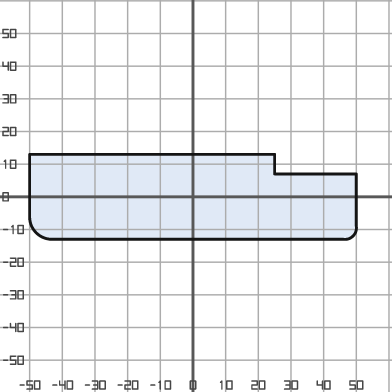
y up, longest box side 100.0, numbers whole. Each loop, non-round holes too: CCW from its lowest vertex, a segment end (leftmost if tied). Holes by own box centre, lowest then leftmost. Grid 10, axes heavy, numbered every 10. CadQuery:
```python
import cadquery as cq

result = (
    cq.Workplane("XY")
    .moveTo(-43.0, -13.0)
    .lineTo(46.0, -13.0)
    .threePointArc((49.0, -12.0), (50.0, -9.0))
    .lineTo(50.0, 7.0)
    .lineTo(25.0, 7.0)
    .lineTo(25.0, 13.0)
    .lineTo(-50.0, 13.0)
    .lineTo(-50.0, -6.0)
    .threePointArc((-48.0, -11.0), (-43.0, -13.0))
    .close()
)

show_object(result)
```